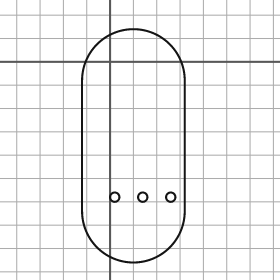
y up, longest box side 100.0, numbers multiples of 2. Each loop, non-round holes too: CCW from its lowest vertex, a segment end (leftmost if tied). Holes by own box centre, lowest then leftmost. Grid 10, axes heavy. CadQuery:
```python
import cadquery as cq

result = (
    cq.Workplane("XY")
    .moveTo(-12.0, -64.0)
    .threePointArc((10.0, -86.0), (32.0, -64.0))
    .lineTo(32.0, -8.0)
    .threePointArc((10.0, 14.0), (-12.0, -8.0))
    .close()
    .moveTo(2.0, -58.0)
    .circle(2.0)
    .moveTo(14.0, -58.0)
    .circle(2.0)
    .moveTo(26.0, -58.0)
    .circle(2.0)
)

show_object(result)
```